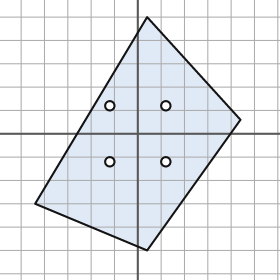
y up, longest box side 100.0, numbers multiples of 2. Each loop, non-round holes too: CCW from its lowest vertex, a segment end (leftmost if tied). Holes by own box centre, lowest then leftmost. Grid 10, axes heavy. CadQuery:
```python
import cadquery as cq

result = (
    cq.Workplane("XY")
    .moveTo(4.0, -50.0)
    .lineTo(44.0, 6.0)
    .lineTo(4.0, 50.0)
    .lineTo(-44.0, -30.0)
    .close()
    .moveTo(-12.0, -12.0)
    .circle(2.0)
    .moveTo(12.0, -12.0)
    .circle(2.0)
    .moveTo(-12.0, 12.0)
    .circle(2.0)
    .moveTo(12.0, 12.0)
    .circle(2.0)
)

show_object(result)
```